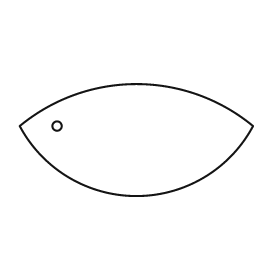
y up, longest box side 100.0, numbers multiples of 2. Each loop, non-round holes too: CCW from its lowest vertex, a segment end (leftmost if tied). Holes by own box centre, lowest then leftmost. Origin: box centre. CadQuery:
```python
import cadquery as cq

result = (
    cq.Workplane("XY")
    .moveTo(-50.0, 6.0)
    .threePointArc((0.0, -24.0), (50.0, 6.0))
    .threePointArc((0.0, 24.0), (-50.0, 6.0))
    .close()
    .moveTo(-34.0, 6.0)
    .circle(2.0)
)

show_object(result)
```